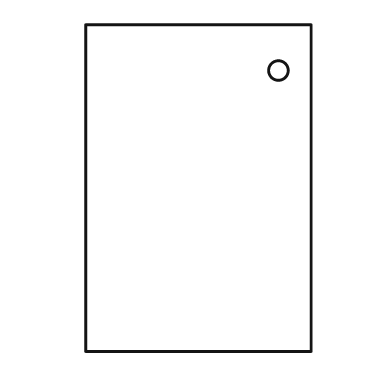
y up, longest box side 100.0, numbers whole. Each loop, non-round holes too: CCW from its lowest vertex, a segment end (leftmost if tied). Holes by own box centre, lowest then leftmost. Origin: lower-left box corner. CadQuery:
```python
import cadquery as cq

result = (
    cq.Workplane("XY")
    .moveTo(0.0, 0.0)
    .lineTo(69.0, 0.0)
    .lineTo(69.0, 100.0)
    .lineTo(0.0, 100.0)
    .close()
    .moveTo(59.0, 86.0)
    .circle(3.0)
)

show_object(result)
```